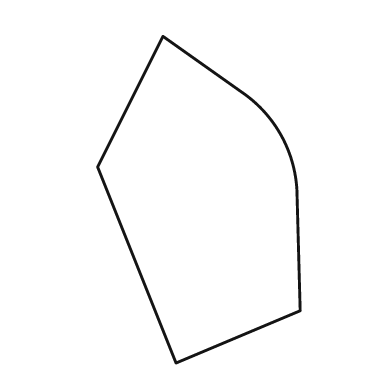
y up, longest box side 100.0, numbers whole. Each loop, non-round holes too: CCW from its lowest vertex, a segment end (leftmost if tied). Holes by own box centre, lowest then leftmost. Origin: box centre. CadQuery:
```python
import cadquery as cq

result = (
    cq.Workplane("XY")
    .moveTo(-7.0, -50.0)
    .lineTo(31.0, -34.0)
    .lineTo(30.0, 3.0)
    .threePointArc((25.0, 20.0), (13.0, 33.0))
    .lineTo(-11.0, 50.0)
    .lineTo(-31.0, 10.0)
    .close()
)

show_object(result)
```